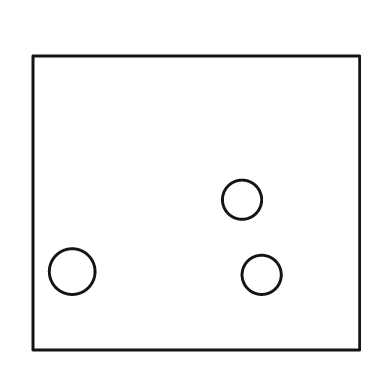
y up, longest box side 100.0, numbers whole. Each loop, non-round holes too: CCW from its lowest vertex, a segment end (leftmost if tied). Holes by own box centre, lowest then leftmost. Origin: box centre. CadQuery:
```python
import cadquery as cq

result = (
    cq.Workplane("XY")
    .moveTo(-50.0, -45.0)
    .lineTo(50.0, -45.0)
    .lineTo(50.0, 45.0)
    .lineTo(-50.0, 45.0)
    .close()
    .moveTo(20.0, -22.0)
    .circle(6.0)
    .moveTo(-38.0, -21.0)
    .circle(7.0)
    .moveTo(14.0, 1.0)
    .circle(6.0)
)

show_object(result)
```